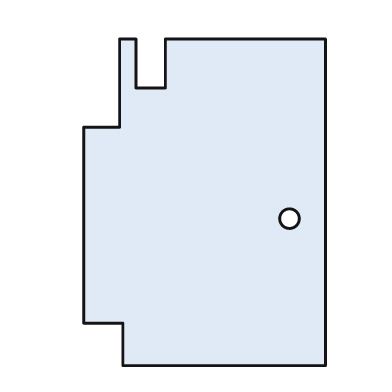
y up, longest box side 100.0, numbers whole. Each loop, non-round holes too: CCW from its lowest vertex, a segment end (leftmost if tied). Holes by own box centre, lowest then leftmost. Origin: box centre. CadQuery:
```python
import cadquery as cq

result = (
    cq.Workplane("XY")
    .moveTo(-25.0, -50.0)
    .lineTo(37.0, -50.0)
    .lineTo(37.0, 50.0)
    .lineTo(-12.0, 50.0)
    .lineTo(-12.0, 35.0)
    .lineTo(-21.0, 35.0)
    .lineTo(-21.0, 50.0)
    .lineTo(-26.0, 50.0)
    .lineTo(-26.0, 23.0)
    .lineTo(-37.0, 23.0)
    .lineTo(-37.0, -37.0)
    .lineTo(-25.0, -37.0)
    .close()
    .moveTo(26.0, -5.0)
    .circle(3.0)
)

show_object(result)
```